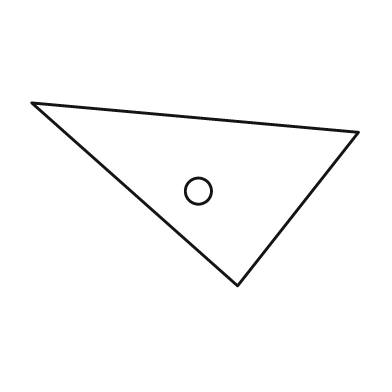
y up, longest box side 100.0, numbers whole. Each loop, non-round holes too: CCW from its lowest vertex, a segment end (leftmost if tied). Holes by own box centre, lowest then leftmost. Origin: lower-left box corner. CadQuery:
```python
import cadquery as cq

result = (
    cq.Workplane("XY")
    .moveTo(63.0, 0.0)
    .lineTo(100.0, 47.0)
    .lineTo(0.0, 56.0)
    .close()
    .moveTo(51.0, 29.0)
    .circle(4.0)
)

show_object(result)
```